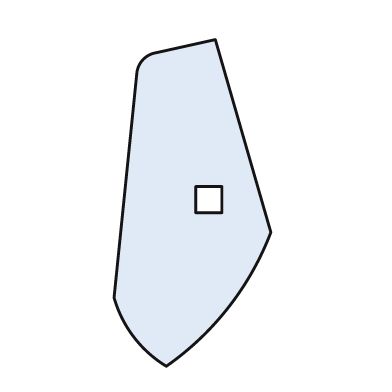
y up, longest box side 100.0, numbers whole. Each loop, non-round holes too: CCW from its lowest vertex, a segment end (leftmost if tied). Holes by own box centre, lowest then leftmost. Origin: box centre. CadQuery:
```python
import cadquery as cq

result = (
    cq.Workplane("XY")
    .moveTo(-8.0, -50.0)
    .threePointArc((11.0, -32.0), (24.0, -9.0))
    .lineTo(7.0, 50.0)
    .lineTo(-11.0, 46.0)
    .threePointArc((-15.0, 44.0), (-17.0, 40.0))
    .lineTo(-24.0, -29.0)
    .threePointArc((-18.0, -41.0), (-8.0, -50.0))
    .close()
    .moveTo(1.0, -3.0)
    .lineTo(9.0, -3.0)
    .lineTo(9.0, 5.0)
    .lineTo(1.0, 5.0)
    .close()
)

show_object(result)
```